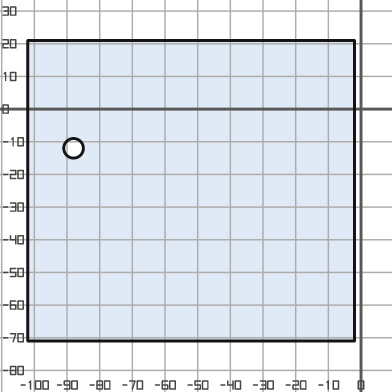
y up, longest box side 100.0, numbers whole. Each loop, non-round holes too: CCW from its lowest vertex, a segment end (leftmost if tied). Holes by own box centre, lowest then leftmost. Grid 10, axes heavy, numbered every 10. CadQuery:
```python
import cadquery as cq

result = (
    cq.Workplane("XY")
    .moveTo(-102.0, -71.0)
    .lineTo(-2.0, -71.0)
    .lineTo(-2.0, 21.0)
    .lineTo(-102.0, 21.0)
    .close()
    .moveTo(-88.0, -12.0)
    .circle(3.0)
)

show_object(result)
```